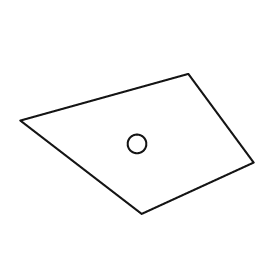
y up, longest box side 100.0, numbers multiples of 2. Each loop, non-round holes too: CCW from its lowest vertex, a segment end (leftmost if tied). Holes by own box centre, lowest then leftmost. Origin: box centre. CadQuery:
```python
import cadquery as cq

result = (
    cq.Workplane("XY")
    .moveTo(2.0, -30.0)
    .lineTo(50.0, -8.0)
    .lineTo(22.0, 30.0)
    .lineTo(-50.0, 10.0)
    .close()
    .moveTo(0.0, 0.0)
    .circle(4.0)
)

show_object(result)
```